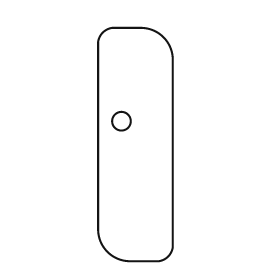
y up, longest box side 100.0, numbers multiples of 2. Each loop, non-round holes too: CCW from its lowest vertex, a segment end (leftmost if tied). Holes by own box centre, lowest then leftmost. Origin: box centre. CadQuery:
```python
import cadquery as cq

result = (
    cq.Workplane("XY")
    .moveTo(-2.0, -50.0)
    .lineTo(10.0, -50.0)
    .threePointArc((14.0, -48.0), (16.0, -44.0))
    .lineTo(16.0, 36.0)
    .threePointArc((12.0, 46.0), (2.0, 50.0))
    .lineTo(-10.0, 50.0)
    .threePointArc((-14.0, 48.0), (-16.0, 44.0))
    .lineTo(-16.0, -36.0)
    .threePointArc((-12.0, -46.0), (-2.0, -50.0))
    .close()
    .moveTo(-6.0, 10.0)
    .circle(4.0)
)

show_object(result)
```